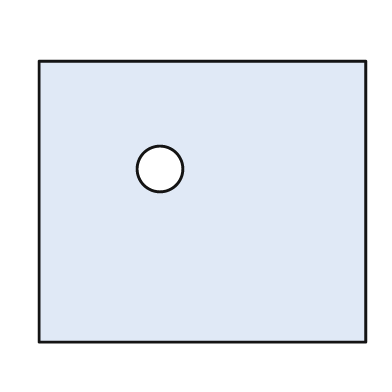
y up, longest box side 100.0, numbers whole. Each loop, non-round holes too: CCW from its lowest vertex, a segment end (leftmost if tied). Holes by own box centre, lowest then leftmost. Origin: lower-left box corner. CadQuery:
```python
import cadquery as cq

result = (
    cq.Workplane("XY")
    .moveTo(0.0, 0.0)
    .lineTo(100.0, 0.0)
    .lineTo(100.0, 86.0)
    .lineTo(0.0, 86.0)
    .close()
    .moveTo(37.0, 53.0)
    .circle(7.0)
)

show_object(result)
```